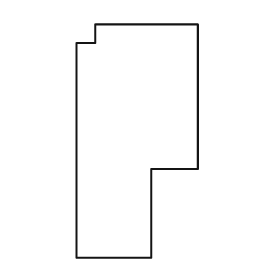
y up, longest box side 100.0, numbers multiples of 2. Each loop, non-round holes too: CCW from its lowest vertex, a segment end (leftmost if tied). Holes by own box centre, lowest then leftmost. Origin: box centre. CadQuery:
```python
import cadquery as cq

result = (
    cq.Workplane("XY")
    .moveTo(-26.0, -50.0)
    .lineTo(6.0, -50.0)
    .lineTo(6.0, -12.0)
    .lineTo(26.0, -12.0)
    .lineTo(26.0, 50.0)
    .lineTo(-18.0, 50.0)
    .lineTo(-18.0, 42.0)
    .lineTo(-26.0, 42.0)
    .close()
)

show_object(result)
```